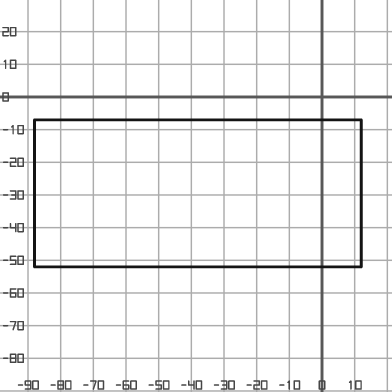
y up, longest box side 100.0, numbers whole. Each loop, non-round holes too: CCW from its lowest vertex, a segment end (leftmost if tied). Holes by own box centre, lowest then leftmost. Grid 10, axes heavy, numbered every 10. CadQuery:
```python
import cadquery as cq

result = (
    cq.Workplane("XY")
    .moveTo(-88.0, -52.0)
    .lineTo(12.0, -52.0)
    .lineTo(12.0, -7.0)
    .lineTo(-88.0, -7.0)
    .close()
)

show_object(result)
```